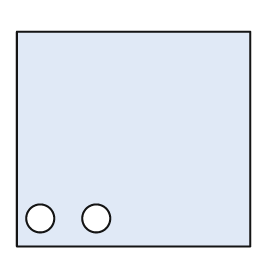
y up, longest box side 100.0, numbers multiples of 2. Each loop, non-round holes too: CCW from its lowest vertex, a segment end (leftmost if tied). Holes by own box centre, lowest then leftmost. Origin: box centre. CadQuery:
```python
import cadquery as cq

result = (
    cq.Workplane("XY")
    .moveTo(-50.0, -46.0)
    .lineTo(50.0, -46.0)
    .lineTo(50.0, 46.0)
    .lineTo(-50.0, 46.0)
    .close()
    .moveTo(-40.0, -34.0)
    .circle(6.0)
    .moveTo(-16.0, -34.0)
    .circle(6.0)
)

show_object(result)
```